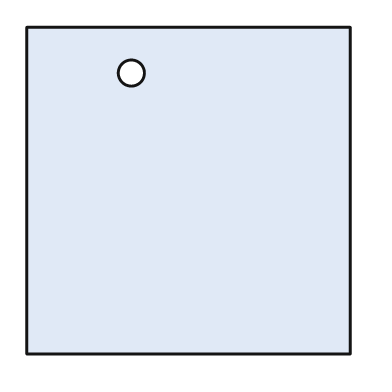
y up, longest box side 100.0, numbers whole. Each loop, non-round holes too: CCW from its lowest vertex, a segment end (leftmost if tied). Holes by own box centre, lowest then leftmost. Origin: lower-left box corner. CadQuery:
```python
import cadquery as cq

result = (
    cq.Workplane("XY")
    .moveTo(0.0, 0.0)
    .lineTo(99.0, 0.0)
    .lineTo(99.0, 100.0)
    .lineTo(0.0, 100.0)
    .close()
    .moveTo(32.0, 86.0)
    .circle(4.0)
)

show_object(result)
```